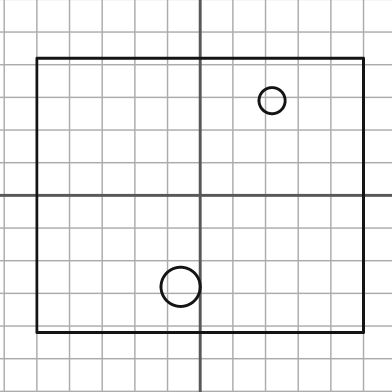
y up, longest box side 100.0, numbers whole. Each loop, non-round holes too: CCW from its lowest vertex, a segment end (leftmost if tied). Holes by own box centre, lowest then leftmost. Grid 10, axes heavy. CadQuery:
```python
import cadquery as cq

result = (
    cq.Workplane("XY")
    .moveTo(-50.0, -42.0)
    .lineTo(50.0, -42.0)
    .lineTo(50.0, 42.0)
    .lineTo(-50.0, 42.0)
    .close()
    .moveTo(-6.0, -28.0)
    .circle(6.0)
    .moveTo(22.0, 29.0)
    .circle(4.0)
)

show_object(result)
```